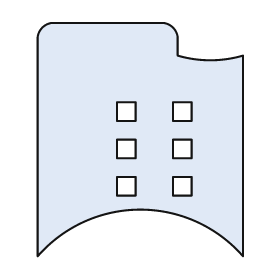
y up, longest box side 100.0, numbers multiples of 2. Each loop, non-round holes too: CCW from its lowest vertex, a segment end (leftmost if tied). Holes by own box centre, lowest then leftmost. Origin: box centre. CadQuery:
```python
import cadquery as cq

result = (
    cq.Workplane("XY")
    .moveTo(-44.0, -50.0)
    .threePointArc((0.0, -30.0), (44.0, -50.0))
    .lineTo(44.0, 36.0)
    .threePointArc((30.0, 34.0), (16.0, 36.0))
    .lineTo(16.0, 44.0)
    .threePointArc((14.0, 48.0), (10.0, 50.0))
    .lineTo(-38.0, 50.0)
    .threePointArc((-42.0, 48.0), (-44.0, 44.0))
    .close()
    .moveTo(-10.0, -24.0)
    .lineTo(-2.0, -24.0)
    .lineTo(-2.0, -16.0)
    .lineTo(-10.0, -16.0)
    .close()
    .moveTo(14.0, -24.0)
    .lineTo(22.0, -24.0)
    .lineTo(22.0, -16.0)
    .lineTo(14.0, -16.0)
    .close()
    .moveTo(-10.0, -8.0)
    .lineTo(-2.0, -8.0)
    .lineTo(-2.0, 0.0)
    .lineTo(-10.0, 0.0)
    .close()
    .moveTo(14.0, -8.0)
    .lineTo(22.0, -8.0)
    .lineTo(22.0, 0.0)
    .lineTo(14.0, 0.0)
    .close()
    .moveTo(-10.0, 8.0)
    .lineTo(-2.0, 8.0)
    .lineTo(-2.0, 16.0)
    .lineTo(-10.0, 16.0)
    .close()
    .moveTo(14.0, 8.0)
    .lineTo(22.0, 8.0)
    .lineTo(22.0, 16.0)
    .lineTo(14.0, 16.0)
    .close()
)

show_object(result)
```